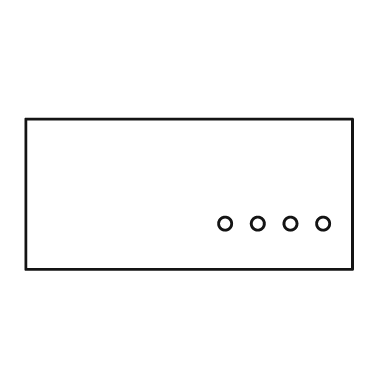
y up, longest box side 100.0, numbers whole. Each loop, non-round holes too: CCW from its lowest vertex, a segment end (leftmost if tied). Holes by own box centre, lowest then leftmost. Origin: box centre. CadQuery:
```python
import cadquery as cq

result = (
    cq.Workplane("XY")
    .moveTo(-50.0, -23.0)
    .lineTo(50.0, -23.0)
    .lineTo(50.0, 23.0)
    .lineTo(-50.0, 23.0)
    .close()
    .moveTo(11.0, -9.0)
    .circle(2.0)
    .moveTo(21.0, -9.0)
    .circle(2.0)
    .moveTo(31.0, -9.0)
    .circle(2.0)
    .moveTo(41.0, -9.0)
    .circle(2.0)
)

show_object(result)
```